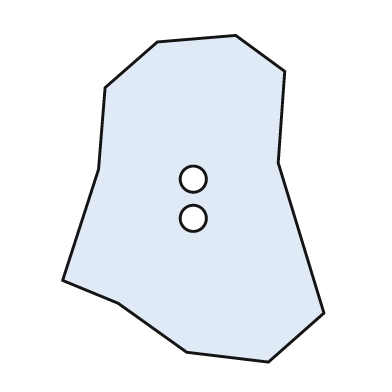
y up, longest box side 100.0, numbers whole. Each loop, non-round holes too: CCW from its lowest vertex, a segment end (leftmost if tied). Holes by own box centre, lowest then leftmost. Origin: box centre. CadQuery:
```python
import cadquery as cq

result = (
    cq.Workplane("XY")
    .moveTo(23.0, -50.0)
    .lineTo(40.0, -35.0)
    .lineTo(26.0, 11.0)
    .lineTo(28.0, 39.0)
    .lineTo(13.0, 50.0)
    .lineTo(-11.0, 48.0)
    .lineTo(-27.0, 34.0)
    .lineTo(-29.0, 9.0)
    .lineTo(-40.0, -25.0)
    .lineTo(-23.0, -32.0)
    .lineTo(-2.0, -47.0)
    .close()
    .moveTo(0.0, -6.0)
    .circle(4.0)
    .moveTo(0.0, 6.0)
    .circle(4.0)
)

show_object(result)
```